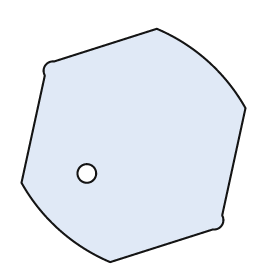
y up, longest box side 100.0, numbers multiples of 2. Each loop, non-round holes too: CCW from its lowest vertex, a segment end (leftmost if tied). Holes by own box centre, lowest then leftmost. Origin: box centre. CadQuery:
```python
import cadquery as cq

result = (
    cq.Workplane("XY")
    .moveTo(-10.0, -50.0)
    .lineTo(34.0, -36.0)
    .threePointArc((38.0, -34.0), (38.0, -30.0))
    .lineTo(48.0, 16.0)
    .threePointArc((32.0, 36.0), (10.0, 50.0))
    .lineTo(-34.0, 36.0)
    .threePointArc((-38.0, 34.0), (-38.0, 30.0))
    .lineTo(-48.0, -16.0)
    .threePointArc((-32.0, -36.0), (-10.0, -50.0))
    .close()
    .moveTo(-20.0, -12.0)
    .circle(4.0)
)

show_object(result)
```